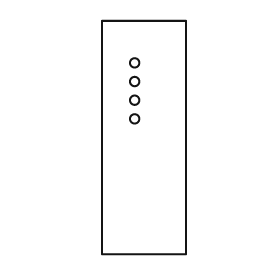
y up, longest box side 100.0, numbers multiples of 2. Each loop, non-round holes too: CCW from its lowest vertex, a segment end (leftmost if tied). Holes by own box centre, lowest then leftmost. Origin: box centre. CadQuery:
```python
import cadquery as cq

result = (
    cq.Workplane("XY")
    .moveTo(-18.0, -50.0)
    .lineTo(18.0, -50.0)
    .lineTo(18.0, 50.0)
    .lineTo(-18.0, 50.0)
    .close()
    .moveTo(-4.0, 8.0)
    .circle(2.0)
    .moveTo(-4.0, 16.0)
    .circle(2.0)
    .moveTo(-4.0, 24.0)
    .circle(2.0)
    .moveTo(-4.0, 32.0)
    .circle(2.0)
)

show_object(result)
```